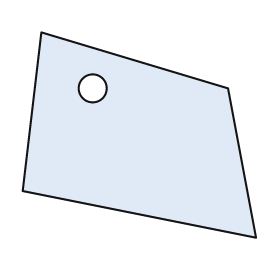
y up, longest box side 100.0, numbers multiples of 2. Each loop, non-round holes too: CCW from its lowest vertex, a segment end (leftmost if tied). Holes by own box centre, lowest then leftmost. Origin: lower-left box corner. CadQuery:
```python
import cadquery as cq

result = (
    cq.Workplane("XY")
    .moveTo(100.0, 0.0)
    .lineTo(88.0, 64.0)
    .lineTo(8.0, 88.0)
    .lineTo(0.0, 20.0)
    .close()
    .moveTo(30.0, 64.0)
    .circle(6.0)
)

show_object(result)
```